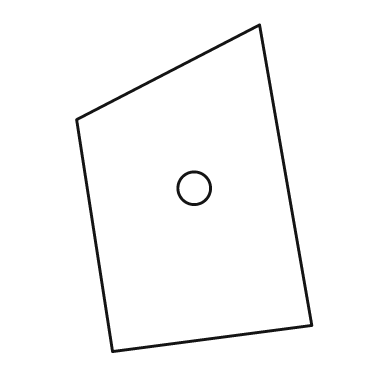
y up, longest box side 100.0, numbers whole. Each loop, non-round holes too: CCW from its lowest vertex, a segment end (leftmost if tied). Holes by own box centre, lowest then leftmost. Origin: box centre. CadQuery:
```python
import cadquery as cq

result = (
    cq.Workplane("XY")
    .moveTo(-25.0, -50.0)
    .lineTo(36.0, -42.0)
    .lineTo(20.0, 50.0)
    .lineTo(-36.0, 21.0)
    .close()
    .moveTo(0.0, 0.0)
    .circle(5.0)
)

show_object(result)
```